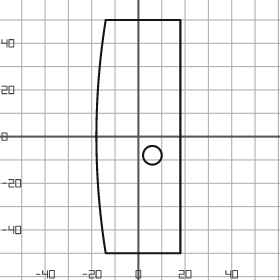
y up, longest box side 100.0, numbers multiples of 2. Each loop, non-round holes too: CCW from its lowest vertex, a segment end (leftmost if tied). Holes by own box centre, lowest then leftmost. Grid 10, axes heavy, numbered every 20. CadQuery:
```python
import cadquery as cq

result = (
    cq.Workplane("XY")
    .moveTo(-14.0, -50.0)
    .lineTo(18.0, -50.0)
    .lineTo(18.0, 50.0)
    .lineTo(-14.0, 50.0)
    .threePointArc((-18.0, 0.0), (-14.0, -50.0))
    .close()
    .moveTo(6.0, -8.0)
    .circle(4.0)
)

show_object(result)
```